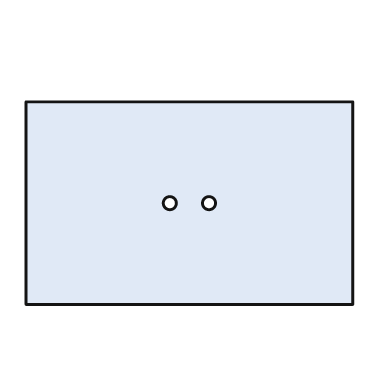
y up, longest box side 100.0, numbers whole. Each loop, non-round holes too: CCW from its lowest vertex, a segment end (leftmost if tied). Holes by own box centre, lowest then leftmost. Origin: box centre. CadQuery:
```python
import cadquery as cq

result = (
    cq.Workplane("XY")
    .moveTo(-50.0, -31.0)
    .lineTo(50.0, -31.0)
    .lineTo(50.0, 31.0)
    .lineTo(-50.0, 31.0)
    .close()
    .moveTo(-6.0, 0.0)
    .circle(2.0)
    .moveTo(6.0, 0.0)
    .circle(2.0)
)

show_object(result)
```